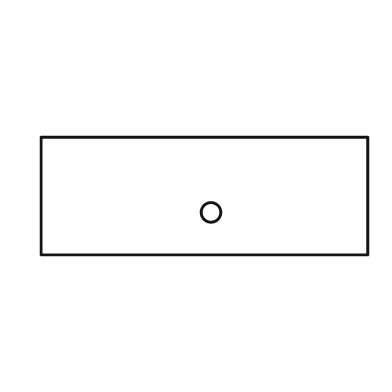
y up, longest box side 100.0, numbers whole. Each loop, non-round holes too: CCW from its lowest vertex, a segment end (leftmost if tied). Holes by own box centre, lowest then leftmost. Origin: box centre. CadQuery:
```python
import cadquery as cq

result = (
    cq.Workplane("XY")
    .moveTo(-50.0, -18.0)
    .lineTo(50.0, -18.0)
    .lineTo(50.0, 18.0)
    .lineTo(-50.0, 18.0)
    .close()
    .moveTo(2.0, -5.0)
    .circle(3.0)
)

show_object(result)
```